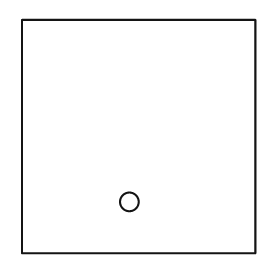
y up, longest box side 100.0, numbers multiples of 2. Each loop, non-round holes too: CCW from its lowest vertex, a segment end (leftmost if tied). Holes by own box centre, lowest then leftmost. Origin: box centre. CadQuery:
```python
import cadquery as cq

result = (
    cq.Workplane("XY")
    .moveTo(-50.0, -50.0)
    .lineTo(50.0, -50.0)
    .lineTo(50.0, 50.0)
    .lineTo(-50.0, 50.0)
    .close()
    .moveTo(-4.0, -28.0)
    .circle(4.0)
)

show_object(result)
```